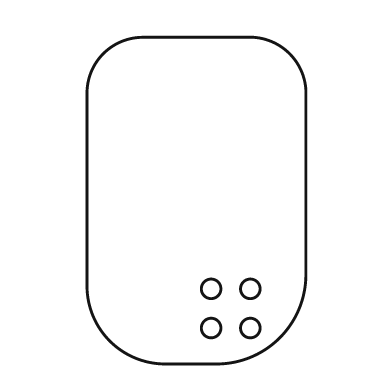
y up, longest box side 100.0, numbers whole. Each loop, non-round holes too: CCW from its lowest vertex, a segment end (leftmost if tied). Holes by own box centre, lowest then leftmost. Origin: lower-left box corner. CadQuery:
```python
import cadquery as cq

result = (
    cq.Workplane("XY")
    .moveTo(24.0, 0.0)
    .lineTo(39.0, 0.0)
    .threePointArc((59.0, 8.0), (67.0, 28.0))
    .lineTo(67.0, 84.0)
    .threePointArc((62.0, 95.0), (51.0, 100.0))
    .lineTo(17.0, 100.0)
    .threePointArc((5.0, 95.0), (0.0, 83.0))
    .lineTo(0.0, 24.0)
    .threePointArc((7.0, 7.0), (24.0, 0.0))
    .close()
    .moveTo(38.0, 11.0)
    .circle(3.0)
    .moveTo(50.0, 11.0)
    .circle(3.0)
    .moveTo(38.0, 23.0)
    .circle(3.0)
    .moveTo(50.0, 23.0)
    .circle(3.0)
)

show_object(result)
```